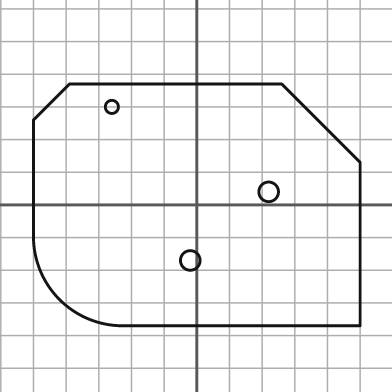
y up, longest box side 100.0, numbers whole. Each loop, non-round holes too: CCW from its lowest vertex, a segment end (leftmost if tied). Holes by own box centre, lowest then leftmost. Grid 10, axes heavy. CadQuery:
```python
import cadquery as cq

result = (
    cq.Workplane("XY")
    .moveTo(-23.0, -37.0)
    .lineTo(50.0, -37.0)
    .lineTo(50.0, 13.0)
    .lineTo(26.0, 37.0)
    .lineTo(-39.0, 37.0)
    .lineTo(-50.0, 26.0)
    .lineTo(-50.0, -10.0)
    .threePointArc((-42.0, -29.0), (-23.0, -37.0))
    .close()
    .moveTo(-2.0, -17.0)
    .circle(3.0)
    .moveTo(22.0, 4.0)
    .circle(3.0)
    .moveTo(-26.0, 30.0)
    .circle(2.0)
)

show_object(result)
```